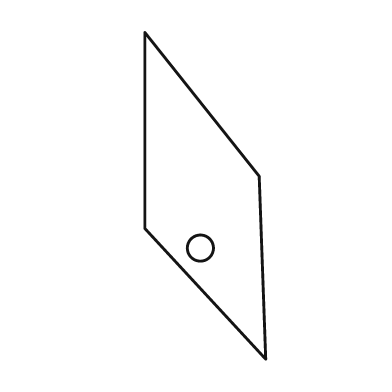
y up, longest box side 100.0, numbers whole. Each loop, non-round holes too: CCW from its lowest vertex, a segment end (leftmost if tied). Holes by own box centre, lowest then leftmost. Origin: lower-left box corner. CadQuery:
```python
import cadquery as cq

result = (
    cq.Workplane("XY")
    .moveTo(37.0, 0.0)
    .lineTo(35.0, 56.0)
    .lineTo(0.0, 100.0)
    .lineTo(0.0, 40.0)
    .close()
    .moveTo(17.0, 34.0)
    .circle(4.0)
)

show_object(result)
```